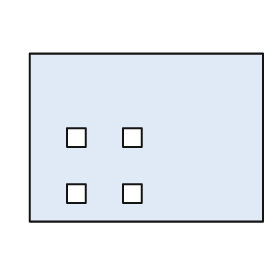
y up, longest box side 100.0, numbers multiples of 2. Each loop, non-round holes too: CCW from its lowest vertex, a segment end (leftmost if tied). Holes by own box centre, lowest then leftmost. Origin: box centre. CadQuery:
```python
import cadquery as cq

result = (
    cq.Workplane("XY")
    .moveTo(-50.0, -36.0)
    .lineTo(50.0, -36.0)
    .lineTo(50.0, 36.0)
    .lineTo(-50.0, 36.0)
    .close()
    .moveTo(-34.0, -28.0)
    .lineTo(-26.0, -28.0)
    .lineTo(-26.0, -20.0)
    .lineTo(-34.0, -20.0)
    .close()
    .moveTo(-10.0, -28.0)
    .lineTo(-2.0, -28.0)
    .lineTo(-2.0, -20.0)
    .lineTo(-10.0, -20.0)
    .close()
    .moveTo(-34.0, -4.0)
    .lineTo(-26.0, -4.0)
    .lineTo(-26.0, 4.0)
    .lineTo(-34.0, 4.0)
    .close()
    .moveTo(-10.0, -4.0)
    .lineTo(-2.0, -4.0)
    .lineTo(-2.0, 4.0)
    .lineTo(-10.0, 4.0)
    .close()
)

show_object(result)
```